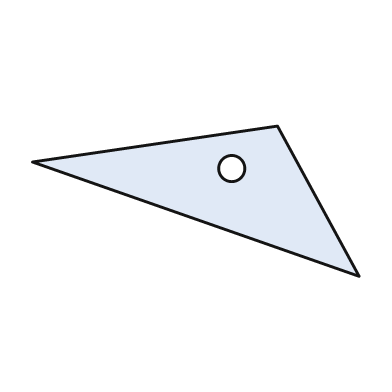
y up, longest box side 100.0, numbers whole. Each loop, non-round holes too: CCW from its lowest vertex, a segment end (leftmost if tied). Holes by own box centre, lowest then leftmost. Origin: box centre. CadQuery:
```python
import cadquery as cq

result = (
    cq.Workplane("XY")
    .moveTo(50.0, -23.0)
    .lineTo(25.0, 23.0)
    .lineTo(-50.0, 12.0)
    .close()
    .moveTo(11.0, 10.0)
    .circle(4.0)
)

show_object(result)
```